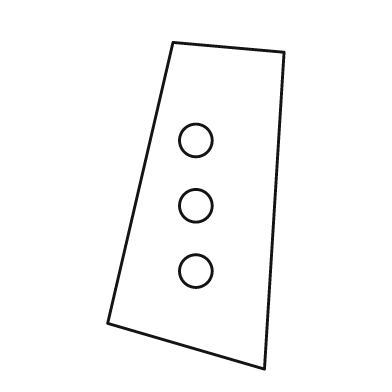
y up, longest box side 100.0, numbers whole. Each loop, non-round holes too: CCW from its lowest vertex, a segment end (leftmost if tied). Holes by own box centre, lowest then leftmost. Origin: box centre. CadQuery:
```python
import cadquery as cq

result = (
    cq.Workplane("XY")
    .moveTo(21.0, -50.0)
    .lineTo(27.0, 47.0)
    .lineTo(-7.0, 50.0)
    .lineTo(-27.0, -36.0)
    .close()
    .moveTo(0.0, -20.0)
    .circle(5.0)
    .moveTo(0.0, 0.0)
    .circle(5.0)
    .moveTo(0.0, 20.0)
    .circle(5.0)
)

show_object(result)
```